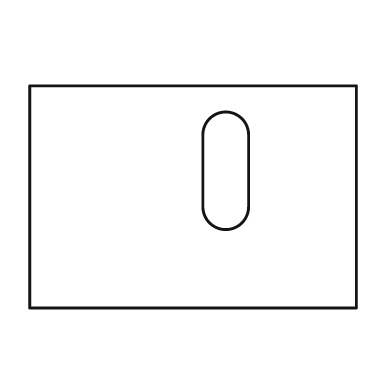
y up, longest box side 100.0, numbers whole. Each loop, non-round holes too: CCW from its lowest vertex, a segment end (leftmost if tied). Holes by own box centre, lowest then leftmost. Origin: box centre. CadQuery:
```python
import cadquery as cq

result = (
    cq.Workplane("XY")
    .moveTo(-50.0, -34.0)
    .lineTo(50.0, -34.0)
    .lineTo(50.0, 34.0)
    .lineTo(-50.0, 34.0)
    .close()
    .moveTo(3.0, -3.0)
    .threePointArc((10.0, -10.0), (17.0, -3.0))
    .lineTo(17.0, 19.0)
    .threePointArc((10.0, 26.0), (3.0, 19.0))
    .close()
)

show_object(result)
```